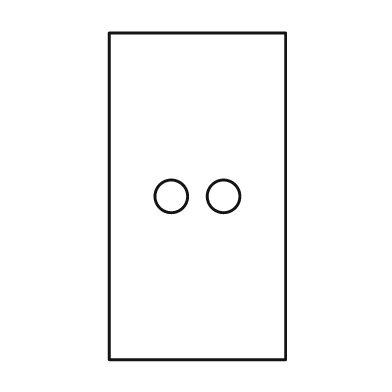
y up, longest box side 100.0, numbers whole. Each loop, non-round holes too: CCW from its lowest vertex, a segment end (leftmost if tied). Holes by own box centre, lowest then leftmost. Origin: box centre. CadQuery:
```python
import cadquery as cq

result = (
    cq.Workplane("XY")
    .moveTo(-27.0, -50.0)
    .lineTo(27.0, -50.0)
    .lineTo(27.0, 50.0)
    .lineTo(-27.0, 50.0)
    .close()
    .moveTo(-8.0, 0.0)
    .circle(5.0)
    .moveTo(8.0, 0.0)
    .circle(5.0)
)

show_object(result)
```